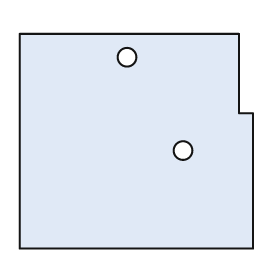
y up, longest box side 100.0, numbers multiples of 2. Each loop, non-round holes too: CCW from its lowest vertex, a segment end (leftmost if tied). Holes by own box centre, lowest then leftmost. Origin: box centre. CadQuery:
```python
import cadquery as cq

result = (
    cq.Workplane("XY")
    .moveTo(-50.0, -46.0)
    .lineTo(50.0, -46.0)
    .lineTo(50.0, 12.0)
    .lineTo(44.0, 12.0)
    .lineTo(44.0, 46.0)
    .lineTo(-50.0, 46.0)
    .close()
    .moveTo(20.0, -4.0)
    .circle(4.0)
    .moveTo(-4.0, 36.0)
    .circle(4.0)
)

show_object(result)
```